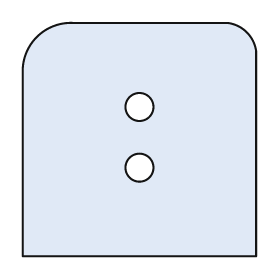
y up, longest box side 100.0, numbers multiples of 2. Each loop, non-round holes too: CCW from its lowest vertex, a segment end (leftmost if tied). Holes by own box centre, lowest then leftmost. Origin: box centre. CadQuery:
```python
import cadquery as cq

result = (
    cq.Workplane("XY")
    .moveTo(-50.0, -50.0)
    .lineTo(50.0, -50.0)
    .lineTo(50.0, 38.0)
    .threePointArc((46.0, 46.0), (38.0, 50.0))
    .lineTo(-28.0, 50.0)
    .threePointArc((-44.0, 44.0), (-50.0, 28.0))
    .close()
    .moveTo(0.0, -12.0)
    .circle(6.0)
    .moveTo(0.0, 14.0)
    .circle(6.0)
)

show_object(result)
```